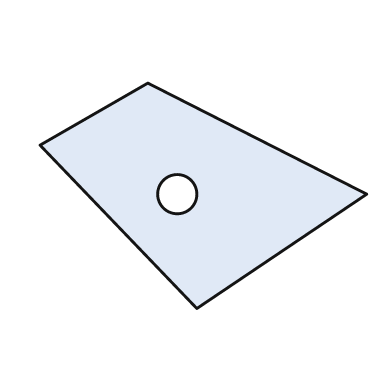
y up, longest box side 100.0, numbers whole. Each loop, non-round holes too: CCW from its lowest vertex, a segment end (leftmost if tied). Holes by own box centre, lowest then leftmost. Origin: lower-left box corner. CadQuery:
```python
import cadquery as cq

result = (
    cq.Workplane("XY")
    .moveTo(48.0, 0.0)
    .lineTo(100.0, 35.0)
    .lineTo(33.0, 69.0)
    .lineTo(0.0, 50.0)
    .close()
    .moveTo(42.0, 35.0)
    .circle(6.0)
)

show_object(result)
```